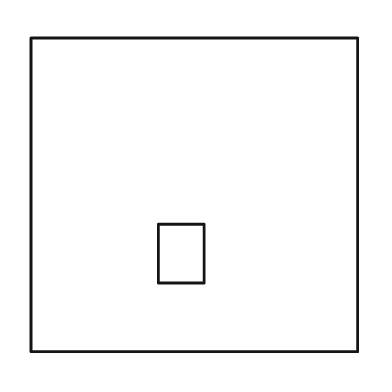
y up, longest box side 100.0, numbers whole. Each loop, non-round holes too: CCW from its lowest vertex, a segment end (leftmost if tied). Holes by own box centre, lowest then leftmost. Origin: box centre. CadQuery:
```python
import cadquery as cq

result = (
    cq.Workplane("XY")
    .moveTo(-50.0, -48.0)
    .lineTo(50.0, -48.0)
    .lineTo(50.0, 48.0)
    .lineTo(-50.0, 48.0)
    .close()
    .moveTo(-11.0, -27.0)
    .lineTo(3.0, -27.0)
    .lineTo(3.0, -9.0)
    .lineTo(-11.0, -9.0)
    .close()
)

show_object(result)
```